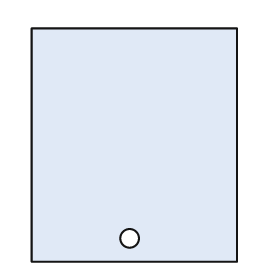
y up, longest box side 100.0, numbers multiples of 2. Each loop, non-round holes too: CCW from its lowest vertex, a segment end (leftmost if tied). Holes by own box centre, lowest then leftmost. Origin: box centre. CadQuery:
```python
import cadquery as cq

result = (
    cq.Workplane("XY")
    .moveTo(-44.0, -50.0)
    .lineTo(44.0, -50.0)
    .lineTo(44.0, 50.0)
    .lineTo(-44.0, 50.0)
    .close()
    .moveTo(-2.0, -40.0)
    .circle(4.0)
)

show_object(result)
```